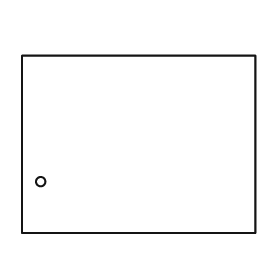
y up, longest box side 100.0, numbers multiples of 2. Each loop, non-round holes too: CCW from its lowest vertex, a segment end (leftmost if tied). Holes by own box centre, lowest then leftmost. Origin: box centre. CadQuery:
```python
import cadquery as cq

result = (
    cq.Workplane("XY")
    .moveTo(-50.0, -38.0)
    .lineTo(50.0, -38.0)
    .lineTo(50.0, 38.0)
    .lineTo(-50.0, 38.0)
    .close()
    .moveTo(-42.0, -16.0)
    .circle(2.0)
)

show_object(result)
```